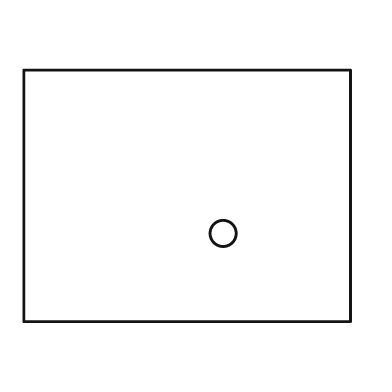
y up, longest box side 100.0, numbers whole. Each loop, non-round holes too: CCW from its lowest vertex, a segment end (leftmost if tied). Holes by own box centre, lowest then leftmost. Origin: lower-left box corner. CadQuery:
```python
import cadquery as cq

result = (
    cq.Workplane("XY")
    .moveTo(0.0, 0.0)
    .lineTo(100.0, 0.0)
    .lineTo(100.0, 77.0)
    .lineTo(0.0, 77.0)
    .close()
    .moveTo(61.0, 27.0)
    .circle(4.0)
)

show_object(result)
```